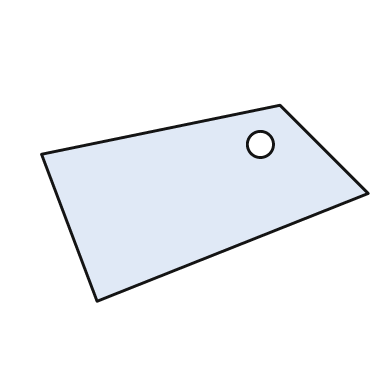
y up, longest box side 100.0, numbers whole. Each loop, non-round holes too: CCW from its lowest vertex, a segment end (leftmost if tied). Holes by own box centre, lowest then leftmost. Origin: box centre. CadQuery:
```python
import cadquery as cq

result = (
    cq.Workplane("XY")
    .moveTo(-33.0, -30.0)
    .lineTo(50.0, 3.0)
    .lineTo(23.0, 30.0)
    .lineTo(-50.0, 15.0)
    .close()
    .moveTo(17.0, 18.0)
    .circle(4.0)
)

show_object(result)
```